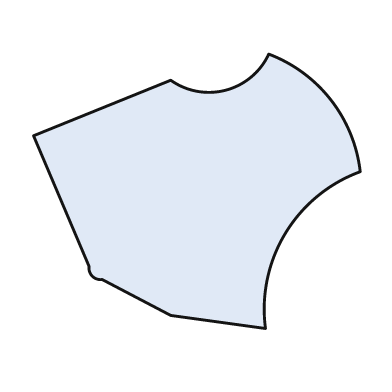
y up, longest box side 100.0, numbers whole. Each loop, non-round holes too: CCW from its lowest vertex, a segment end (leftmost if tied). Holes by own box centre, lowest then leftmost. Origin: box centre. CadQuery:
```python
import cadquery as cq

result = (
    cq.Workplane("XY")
    .moveTo(21.0, -42.0)
    .threePointArc((27.0, -13.0), (50.0, 6.0))
    .threePointArc((41.0, 28.0), (22.0, 42.0))
    .threePointArc((9.0, 31.0), (-8.0, 34.0))
    .lineTo(-50.0, 17.0)
    .lineTo(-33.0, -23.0)
    .threePointArc((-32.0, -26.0), (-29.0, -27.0))
    .lineTo(-8.0, -38.0)
    .close()
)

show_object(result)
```